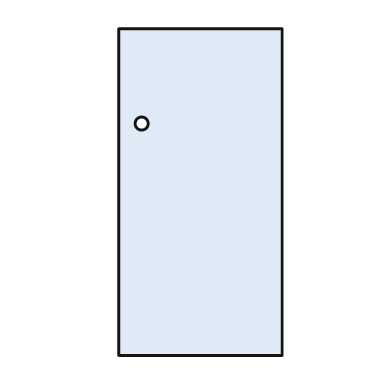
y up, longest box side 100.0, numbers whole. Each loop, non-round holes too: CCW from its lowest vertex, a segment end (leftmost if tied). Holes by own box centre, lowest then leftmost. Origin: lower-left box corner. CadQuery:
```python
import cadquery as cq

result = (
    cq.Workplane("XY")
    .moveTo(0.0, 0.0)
    .lineTo(50.0, 0.0)
    .lineTo(50.0, 100.0)
    .lineTo(0.0, 100.0)
    .close()
    .moveTo(7.0, 71.0)
    .circle(2.0)
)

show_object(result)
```